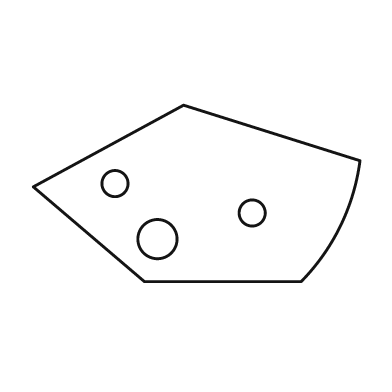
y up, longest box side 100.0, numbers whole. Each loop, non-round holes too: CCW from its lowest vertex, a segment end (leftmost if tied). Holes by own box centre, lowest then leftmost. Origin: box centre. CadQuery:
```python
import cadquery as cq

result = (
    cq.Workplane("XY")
    .moveTo(-16.0, -27.0)
    .lineTo(32.0, -27.0)
    .threePointArc((44.0, -10.0), (50.0, 10.0))
    .lineTo(-4.0, 27.0)
    .lineTo(-50.0, 2.0)
    .close()
    .moveTo(-12.0, -14.0)
    .circle(6.0)
    .moveTo(17.0, -6.0)
    .circle(4.0)
    .moveTo(-25.0, 3.0)
    .circle(4.0)
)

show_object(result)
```